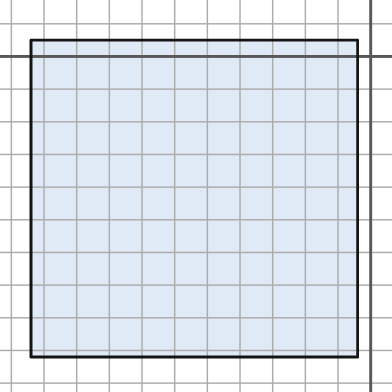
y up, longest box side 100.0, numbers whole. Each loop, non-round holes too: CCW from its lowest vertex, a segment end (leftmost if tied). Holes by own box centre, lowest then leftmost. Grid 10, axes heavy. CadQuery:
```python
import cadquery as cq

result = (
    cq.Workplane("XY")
    .moveTo(-104.0, -92.0)
    .lineTo(-4.0, -92.0)
    .lineTo(-4.0, 5.0)
    .lineTo(-104.0, 5.0)
    .close()
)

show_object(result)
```